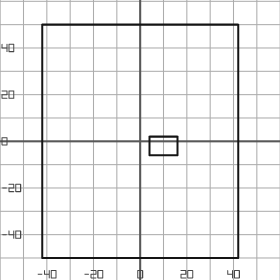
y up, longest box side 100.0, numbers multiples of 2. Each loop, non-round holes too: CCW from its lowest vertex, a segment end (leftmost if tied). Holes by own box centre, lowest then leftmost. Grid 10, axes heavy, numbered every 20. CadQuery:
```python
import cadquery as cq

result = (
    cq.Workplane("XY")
    .moveTo(-42.0, -50.0)
    .lineTo(42.0, -50.0)
    .lineTo(42.0, 50.0)
    .lineTo(-42.0, 50.0)
    .close()
    .moveTo(4.0, -6.0)
    .lineTo(16.0, -6.0)
    .lineTo(16.0, 2.0)
    .lineTo(4.0, 2.0)
    .close()
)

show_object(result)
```